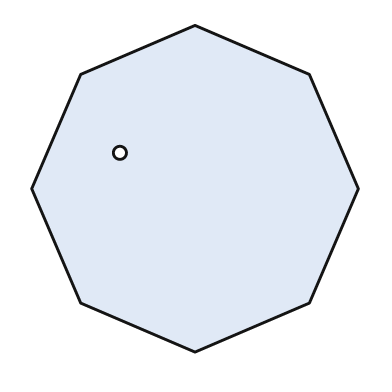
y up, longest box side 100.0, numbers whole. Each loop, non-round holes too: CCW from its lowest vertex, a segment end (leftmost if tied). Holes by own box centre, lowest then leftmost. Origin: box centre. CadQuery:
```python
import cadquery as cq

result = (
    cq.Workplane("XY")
    .moveTo(0.0, -50.0)
    .lineTo(35.0, -35.0)
    .lineTo(50.0, 0.0)
    .lineTo(35.0, 35.0)
    .lineTo(0.0, 50.0)
    .lineTo(-35.0, 35.0)
    .lineTo(-50.0, 0.0)
    .lineTo(-35.0, -35.0)
    .close()
    .moveTo(-23.0, 11.0)
    .circle(2.0)
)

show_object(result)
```